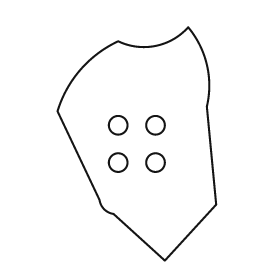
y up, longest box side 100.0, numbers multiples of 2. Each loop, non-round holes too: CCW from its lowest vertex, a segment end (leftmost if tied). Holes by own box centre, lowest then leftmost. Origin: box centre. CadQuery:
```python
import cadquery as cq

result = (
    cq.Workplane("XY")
    .moveTo(12.0, -50.0)
    .lineTo(34.0, -26.0)
    .lineTo(30.0, 16.0)
    .threePointArc((30.0, 34.0), (22.0, 50.0))
    .threePointArc((8.0, 42.0), (-8.0, 44.0))
    .threePointArc((-24.0, 32.0), (-34.0, 14.0))
    .lineTo(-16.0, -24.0)
    .threePointArc((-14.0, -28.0), (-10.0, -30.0))
    .close()
    .moveTo(-8.0, -8.0)
    .circle(4.0)
    .moveTo(8.0, -8.0)
    .circle(4.0)
    .moveTo(-8.0, 8.0)
    .circle(4.0)
    .moveTo(8.0, 8.0)
    .circle(4.0)
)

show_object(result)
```